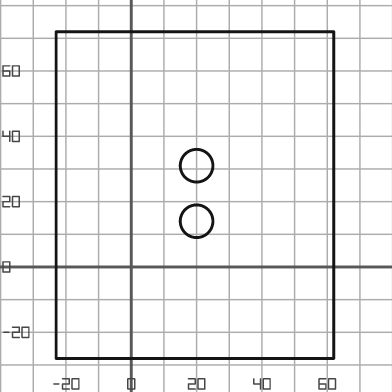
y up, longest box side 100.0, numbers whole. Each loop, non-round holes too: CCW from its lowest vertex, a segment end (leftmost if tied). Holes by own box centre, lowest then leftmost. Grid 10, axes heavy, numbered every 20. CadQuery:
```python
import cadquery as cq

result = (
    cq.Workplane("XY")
    .moveTo(-23.0, -28.0)
    .lineTo(62.0, -28.0)
    .lineTo(62.0, 72.0)
    .lineTo(-23.0, 72.0)
    .close()
    .moveTo(20.0, 14.0)
    .circle(5.0)
    .moveTo(20.0, 31.0)
    .circle(5.0)
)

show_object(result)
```